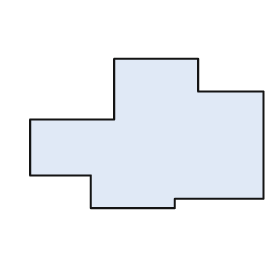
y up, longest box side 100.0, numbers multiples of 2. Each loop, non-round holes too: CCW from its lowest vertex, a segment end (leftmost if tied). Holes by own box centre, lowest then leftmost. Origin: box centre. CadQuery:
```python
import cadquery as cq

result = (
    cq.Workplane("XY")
    .moveTo(-24.0, -32.0)
    .lineTo(12.0, -32.0)
    .lineTo(12.0, -28.0)
    .lineTo(50.0, -28.0)
    .lineTo(50.0, 18.0)
    .lineTo(22.0, 18.0)
    .lineTo(22.0, 32.0)
    .lineTo(-14.0, 32.0)
    .lineTo(-14.0, 6.0)
    .lineTo(-50.0, 6.0)
    .lineTo(-50.0, -18.0)
    .lineTo(-24.0, -18.0)
    .close()
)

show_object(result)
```